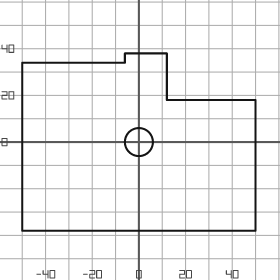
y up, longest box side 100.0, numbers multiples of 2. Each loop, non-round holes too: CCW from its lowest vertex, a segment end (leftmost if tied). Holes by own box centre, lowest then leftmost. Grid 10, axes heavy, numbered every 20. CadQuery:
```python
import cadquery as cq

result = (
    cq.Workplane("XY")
    .moveTo(-50.0, -38.0)
    .lineTo(50.0, -38.0)
    .lineTo(50.0, 18.0)
    .lineTo(12.0, 18.0)
    .lineTo(12.0, 38.0)
    .lineTo(-6.0, 38.0)
    .lineTo(-6.0, 34.0)
    .lineTo(-50.0, 34.0)
    .close()
    .moveTo(0.0, 0.0)
    .circle(6.0)
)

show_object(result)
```